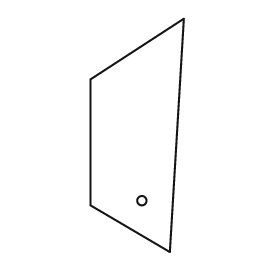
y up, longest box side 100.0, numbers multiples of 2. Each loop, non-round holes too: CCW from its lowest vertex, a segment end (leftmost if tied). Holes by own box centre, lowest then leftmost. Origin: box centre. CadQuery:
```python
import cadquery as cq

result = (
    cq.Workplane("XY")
    .moveTo(14.0, -50.0)
    .lineTo(20.0, 50.0)
    .lineTo(-20.0, 24.0)
    .lineTo(-20.0, -30.0)
    .close()
    .moveTo(2.0, -28.0)
    .circle(2.0)
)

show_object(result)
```